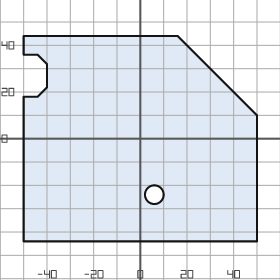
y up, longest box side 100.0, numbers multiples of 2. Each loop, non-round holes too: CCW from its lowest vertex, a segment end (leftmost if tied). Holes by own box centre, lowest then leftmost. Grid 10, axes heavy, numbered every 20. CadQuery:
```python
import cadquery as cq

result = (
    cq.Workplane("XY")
    .moveTo(-50.0, -44.0)
    .lineTo(50.0, -44.0)
    .lineTo(50.0, 10.0)
    .lineTo(16.0, 44.0)
    .lineTo(-50.0, 44.0)
    .lineTo(-50.0, 36.0)
    .lineTo(-44.0, 36.0)
    .lineTo(-40.0, 32.0)
    .lineTo(-40.0, 22.0)
    .lineTo(-44.0, 18.0)
    .lineTo(-50.0, 18.0)
    .close()
    .moveTo(6.0, -24.0)
    .circle(4.0)
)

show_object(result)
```